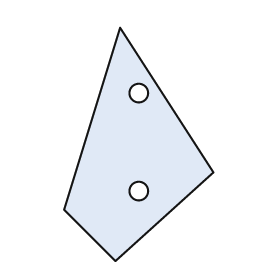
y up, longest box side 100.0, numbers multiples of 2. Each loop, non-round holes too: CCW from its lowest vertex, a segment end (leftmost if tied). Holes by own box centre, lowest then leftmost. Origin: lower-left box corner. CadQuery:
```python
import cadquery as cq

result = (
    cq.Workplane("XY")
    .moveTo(22.0, 0.0)
    .lineTo(64.0, 38.0)
    .lineTo(24.0, 100.0)
    .lineTo(0.0, 22.0)
    .close()
    .moveTo(32.0, 30.0)
    .circle(4.0)
    .moveTo(32.0, 72.0)
    .circle(4.0)
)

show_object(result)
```